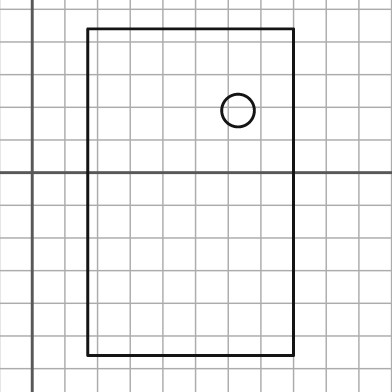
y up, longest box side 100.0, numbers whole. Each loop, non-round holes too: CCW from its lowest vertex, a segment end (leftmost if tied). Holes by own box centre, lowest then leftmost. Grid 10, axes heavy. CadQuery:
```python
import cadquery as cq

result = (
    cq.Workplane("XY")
    .moveTo(17.0, -56.0)
    .lineTo(80.0, -56.0)
    .lineTo(80.0, 44.0)
    .lineTo(17.0, 44.0)
    .close()
    .moveTo(63.0, 19.0)
    .circle(5.0)
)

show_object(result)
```